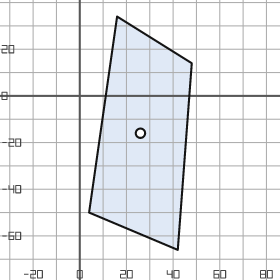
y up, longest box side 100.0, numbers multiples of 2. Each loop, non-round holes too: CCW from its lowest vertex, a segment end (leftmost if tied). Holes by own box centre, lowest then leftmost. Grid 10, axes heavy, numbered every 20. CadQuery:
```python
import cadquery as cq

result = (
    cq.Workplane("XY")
    .moveTo(42.0, -66.0)
    .lineTo(48.0, 14.0)
    .lineTo(16.0, 34.0)
    .lineTo(4.0, -50.0)
    .close()
    .moveTo(26.0, -16.0)
    .circle(2.0)
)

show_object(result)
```